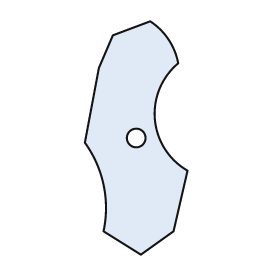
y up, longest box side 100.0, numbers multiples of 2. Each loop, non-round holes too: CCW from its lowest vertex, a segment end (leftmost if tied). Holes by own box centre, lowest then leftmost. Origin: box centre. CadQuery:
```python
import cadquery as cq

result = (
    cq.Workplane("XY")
    .moveTo(2.0, -50.0)
    .lineTo(16.0, -40.0)
    .lineTo(22.0, -14.0)
    .threePointArc((8.0, 8.0), (18.0, 32.0))
    .threePointArc((14.0, 42.0), (6.0, 50.0))
    .lineTo(-10.0, 44.0)
    .lineTo(-16.0, 30.0)
    .lineTo(-22.0, -2.0)
    .threePointArc((-14.0, -20.0), (-14.0, -40.0))
    .close()
    .moveTo(0.0, 0.0)
    .circle(4.0)
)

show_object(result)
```